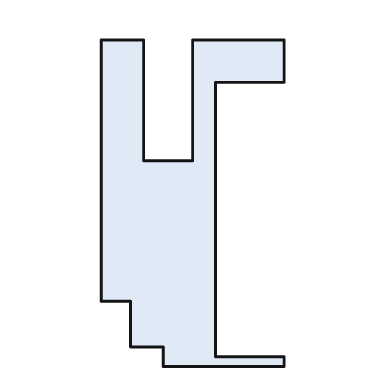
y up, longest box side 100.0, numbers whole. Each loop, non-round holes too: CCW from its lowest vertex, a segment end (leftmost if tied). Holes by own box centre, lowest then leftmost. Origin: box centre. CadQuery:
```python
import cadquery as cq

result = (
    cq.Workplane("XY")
    .moveTo(-9.0, -50.0)
    .lineTo(28.0, -50.0)
    .lineTo(28.0, -47.0)
    .lineTo(7.0, -47.0)
    .lineTo(7.0, 37.0)
    .lineTo(28.0, 37.0)
    .lineTo(28.0, 50.0)
    .lineTo(0.0, 50.0)
    .lineTo(0.0, 13.0)
    .lineTo(-15.0, 13.0)
    .lineTo(-15.0, 50.0)
    .lineTo(-28.0, 50.0)
    .lineTo(-28.0, -30.0)
    .lineTo(-19.0, -30.0)
    .lineTo(-19.0, -44.0)
    .lineTo(-9.0, -44.0)
    .close()
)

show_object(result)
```